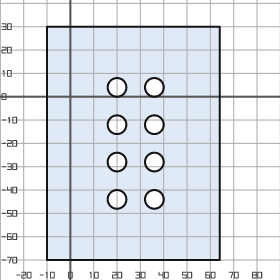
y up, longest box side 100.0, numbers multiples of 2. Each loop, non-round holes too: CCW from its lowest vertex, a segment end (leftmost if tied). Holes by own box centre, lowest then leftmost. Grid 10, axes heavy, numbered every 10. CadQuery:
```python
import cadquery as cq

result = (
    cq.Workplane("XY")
    .moveTo(-10.0, -70.0)
    .lineTo(64.0, -70.0)
    .lineTo(64.0, 30.0)
    .lineTo(-10.0, 30.0)
    .close()
    .moveTo(20.0, -44.0)
    .circle(4.0)
    .moveTo(36.0, -44.0)
    .circle(4.0)
    .moveTo(20.0, -28.0)
    .circle(4.0)
    .moveTo(36.0, -28.0)
    .circle(4.0)
    .moveTo(20.0, -12.0)
    .circle(4.0)
    .moveTo(36.0, -12.0)
    .circle(4.0)
    .moveTo(20.0, 4.0)
    .circle(4.0)
    .moveTo(36.0, 4.0)
    .circle(4.0)
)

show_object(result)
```